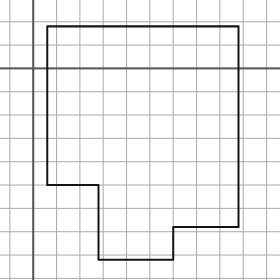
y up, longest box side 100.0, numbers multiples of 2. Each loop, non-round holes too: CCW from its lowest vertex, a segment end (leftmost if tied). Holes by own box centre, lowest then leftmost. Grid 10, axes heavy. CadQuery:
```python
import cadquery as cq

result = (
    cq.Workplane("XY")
    .moveTo(28.0, -82.0)
    .lineTo(60.0, -82.0)
    .lineTo(60.0, -68.0)
    .lineTo(88.0, -68.0)
    .lineTo(88.0, 18.0)
    .lineTo(6.0, 18.0)
    .lineTo(6.0, -50.0)
    .lineTo(28.0, -50.0)
    .close()
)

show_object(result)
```